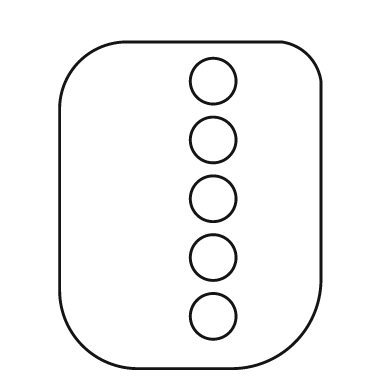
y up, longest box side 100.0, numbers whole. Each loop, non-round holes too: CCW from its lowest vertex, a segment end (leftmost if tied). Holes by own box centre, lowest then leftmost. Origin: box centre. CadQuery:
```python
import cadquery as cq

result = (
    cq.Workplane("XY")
    .moveTo(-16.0, -50.0)
    .lineTo(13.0, -50.0)
    .threePointArc((32.0, -42.0), (40.0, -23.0))
    .lineTo(40.0, 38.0)
    .threePointArc((36.0, 46.0), (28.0, 50.0))
    .lineTo(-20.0, 50.0)
    .threePointArc((-34.0, 44.0), (-40.0, 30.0))
    .lineTo(-40.0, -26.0)
    .threePointArc((-33.0, -43.0), (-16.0, -50.0))
    .close()
    .moveTo(7.0, -34.0)
    .circle(7.0)
    .moveTo(7.0, -16.0)
    .circle(7.0)
    .moveTo(7.0, 2.0)
    .circle(7.0)
    .moveTo(7.0, 20.0)
    .circle(7.0)
    .moveTo(7.0, 38.0)
    .circle(7.0)
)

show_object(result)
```